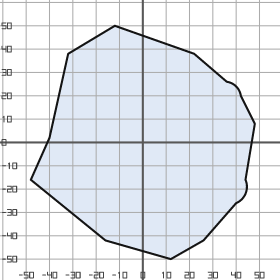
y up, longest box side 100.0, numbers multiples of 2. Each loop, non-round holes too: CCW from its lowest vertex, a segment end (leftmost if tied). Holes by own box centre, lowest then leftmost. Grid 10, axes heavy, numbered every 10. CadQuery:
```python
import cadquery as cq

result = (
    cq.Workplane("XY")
    .moveTo(12.0, -50.0)
    .lineTo(26.0, -42.0)
    .lineTo(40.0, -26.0)
    .threePointArc((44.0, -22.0), (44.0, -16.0))
    .lineTo(48.0, 8.0)
    .lineTo(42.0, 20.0)
    .threePointArc((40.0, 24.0), (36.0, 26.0))
    .lineTo(22.0, 38.0)
    .lineTo(-12.0, 50.0)
    .lineTo(-32.0, 38.0)
    .lineTo(-40.0, 2.0)
    .lineTo(-48.0, -16.0)
    .lineTo(-16.0, -42.0)
    .close()
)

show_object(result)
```